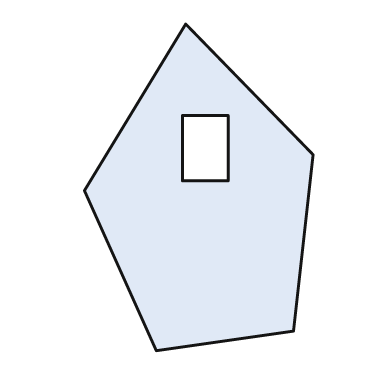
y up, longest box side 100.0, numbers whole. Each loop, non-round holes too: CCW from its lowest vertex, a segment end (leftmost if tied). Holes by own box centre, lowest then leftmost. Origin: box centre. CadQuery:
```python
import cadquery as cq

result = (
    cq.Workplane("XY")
    .moveTo(-13.0, -50.0)
    .lineTo(29.0, -44.0)
    .lineTo(35.0, 10.0)
    .lineTo(-4.0, 50.0)
    .lineTo(-35.0, -1.0)
    .close()
    .moveTo(-5.0, 2.0)
    .lineTo(9.0, 2.0)
    .lineTo(9.0, 22.0)
    .lineTo(-5.0, 22.0)
    .close()
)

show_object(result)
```